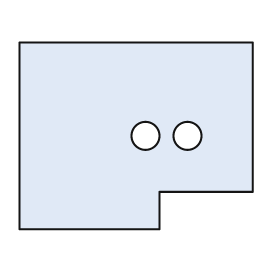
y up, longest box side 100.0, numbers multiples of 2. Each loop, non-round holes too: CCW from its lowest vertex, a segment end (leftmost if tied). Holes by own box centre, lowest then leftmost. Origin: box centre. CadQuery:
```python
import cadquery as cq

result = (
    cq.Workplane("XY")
    .moveTo(-50.0, -40.0)
    .lineTo(10.0, -40.0)
    .lineTo(10.0, -24.0)
    .lineTo(50.0, -24.0)
    .lineTo(50.0, 40.0)
    .lineTo(-50.0, 40.0)
    .close()
    .moveTo(4.0, 0.0)
    .circle(6.0)
    .moveTo(22.0, 0.0)
    .circle(6.0)
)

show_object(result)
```